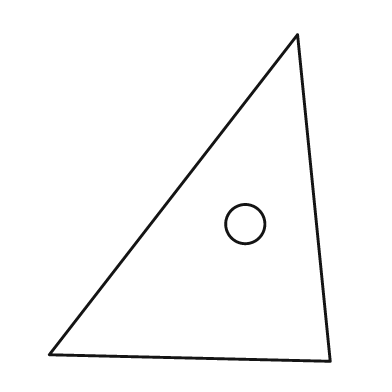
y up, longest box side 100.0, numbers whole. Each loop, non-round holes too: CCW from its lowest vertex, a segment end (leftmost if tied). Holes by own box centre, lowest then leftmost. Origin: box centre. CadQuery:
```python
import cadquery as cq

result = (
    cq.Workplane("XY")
    .moveTo(43.0, -50.0)
    .lineTo(33.0, 50.0)
    .lineTo(-43.0, -48.0)
    .close()
    .moveTo(17.0, -8.0)
    .circle(6.0)
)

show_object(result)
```